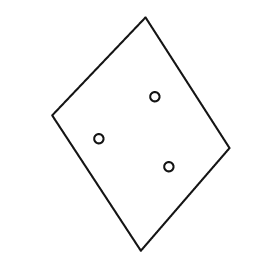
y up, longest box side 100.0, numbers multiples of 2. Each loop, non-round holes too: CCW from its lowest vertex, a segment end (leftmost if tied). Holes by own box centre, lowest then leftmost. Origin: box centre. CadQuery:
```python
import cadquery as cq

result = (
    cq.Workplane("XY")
    .moveTo(0.0, -50.0)
    .lineTo(38.0, -6.0)
    .lineTo(2.0, 50.0)
    .lineTo(-38.0, 8.0)
    .close()
    .moveTo(12.0, -14.0)
    .circle(2.0)
    .moveTo(-18.0, -2.0)
    .circle(2.0)
    .moveTo(6.0, 16.0)
    .circle(2.0)
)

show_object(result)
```